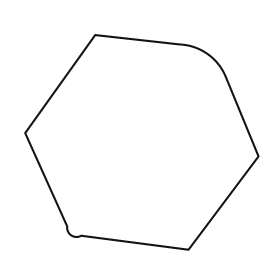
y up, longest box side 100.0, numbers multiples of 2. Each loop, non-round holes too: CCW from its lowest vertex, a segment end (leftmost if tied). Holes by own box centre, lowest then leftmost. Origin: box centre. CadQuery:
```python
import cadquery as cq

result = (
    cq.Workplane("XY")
    .moveTo(20.0, -46.0)
    .lineTo(50.0, -6.0)
    .lineTo(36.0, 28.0)
    .threePointArc((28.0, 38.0), (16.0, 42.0))
    .lineTo(-20.0, 46.0)
    .lineTo(-50.0, 4.0)
    .lineTo(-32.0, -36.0)
    .threePointArc((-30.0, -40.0), (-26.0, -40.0))
    .close()
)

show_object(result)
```